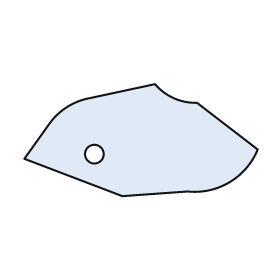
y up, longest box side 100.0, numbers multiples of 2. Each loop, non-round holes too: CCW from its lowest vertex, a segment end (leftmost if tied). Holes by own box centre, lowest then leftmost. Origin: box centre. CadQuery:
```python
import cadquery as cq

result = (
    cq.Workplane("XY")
    .moveTo(-8.0, -24.0)
    .lineTo(20.0, -22.0)
    .threePointArc((38.0, -18.0), (50.0, -4.0))
    .lineTo(24.0, 16.0)
    .threePointArc((14.0, 18.0), (6.0, 24.0))
    .lineTo(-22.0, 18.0)
    .threePointArc((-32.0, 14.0), (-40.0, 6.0))
    .lineTo(-50.0, -8.0)
    .close()
    .moveTo(-20.0, -6.0)
    .circle(4.0)
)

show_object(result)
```